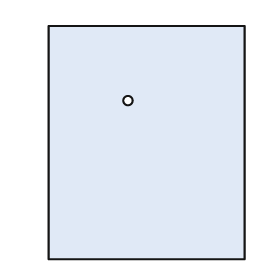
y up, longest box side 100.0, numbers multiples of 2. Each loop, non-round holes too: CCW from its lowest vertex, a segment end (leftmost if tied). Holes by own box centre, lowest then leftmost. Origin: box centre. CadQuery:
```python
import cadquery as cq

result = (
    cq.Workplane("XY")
    .moveTo(-42.0, -50.0)
    .lineTo(42.0, -50.0)
    .lineTo(42.0, 50.0)
    .lineTo(-42.0, 50.0)
    .close()
    .moveTo(-8.0, 18.0)
    .circle(2.0)
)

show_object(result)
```